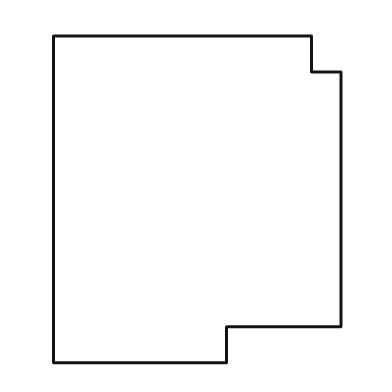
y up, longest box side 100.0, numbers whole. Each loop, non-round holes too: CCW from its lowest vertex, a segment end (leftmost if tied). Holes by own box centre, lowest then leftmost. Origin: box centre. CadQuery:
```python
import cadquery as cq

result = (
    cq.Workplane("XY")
    .moveTo(-44.0, -50.0)
    .lineTo(9.0, -50.0)
    .lineTo(9.0, -39.0)
    .lineTo(44.0, -39.0)
    .lineTo(44.0, 39.0)
    .lineTo(35.0, 39.0)
    .lineTo(35.0, 50.0)
    .lineTo(-44.0, 50.0)
    .close()
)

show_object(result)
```